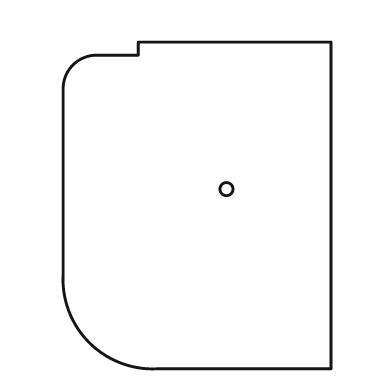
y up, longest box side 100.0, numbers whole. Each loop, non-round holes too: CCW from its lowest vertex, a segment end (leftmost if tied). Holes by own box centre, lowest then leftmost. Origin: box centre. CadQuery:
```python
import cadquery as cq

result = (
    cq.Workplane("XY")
    .moveTo(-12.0, -50.0)
    .lineTo(41.0, -50.0)
    .lineTo(41.0, 50.0)
    .lineTo(-18.0, 50.0)
    .lineTo(-18.0, 46.0)
    .lineTo(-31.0, 46.0)
    .threePointArc((-38.0, 43.0), (-41.0, 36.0))
    .lineTo(-41.0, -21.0)
    .threePointArc((-33.0, -42.0), (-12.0, -50.0))
    .close()
    .moveTo(9.0, 5.0)
    .circle(2.0)
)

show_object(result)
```